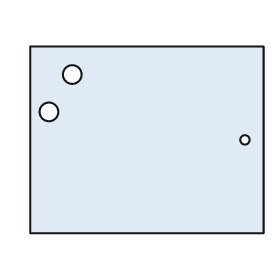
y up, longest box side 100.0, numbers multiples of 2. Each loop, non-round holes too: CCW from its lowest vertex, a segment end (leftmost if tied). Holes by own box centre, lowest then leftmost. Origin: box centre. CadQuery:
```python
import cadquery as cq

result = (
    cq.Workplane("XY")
    .moveTo(-50.0, -40.0)
    .lineTo(50.0, -40.0)
    .lineTo(50.0, 40.0)
    .lineTo(-50.0, 40.0)
    .close()
    .moveTo(42.0, 0.0)
    .circle(2.0)
    .moveTo(-42.0, 12.0)
    .circle(4.0)
    .moveTo(-32.0, 28.0)
    .circle(4.0)
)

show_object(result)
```